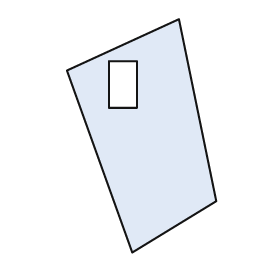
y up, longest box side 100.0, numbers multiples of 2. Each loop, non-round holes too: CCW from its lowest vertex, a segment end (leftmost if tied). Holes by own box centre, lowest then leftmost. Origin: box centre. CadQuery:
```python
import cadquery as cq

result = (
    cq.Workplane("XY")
    .moveTo(-4.0, -50.0)
    .lineTo(32.0, -28.0)
    .lineTo(16.0, 50.0)
    .lineTo(-32.0, 28.0)
    .close()
    .moveTo(-14.0, 12.0)
    .lineTo(-2.0, 12.0)
    .lineTo(-2.0, 32.0)
    .lineTo(-14.0, 32.0)
    .close()
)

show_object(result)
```